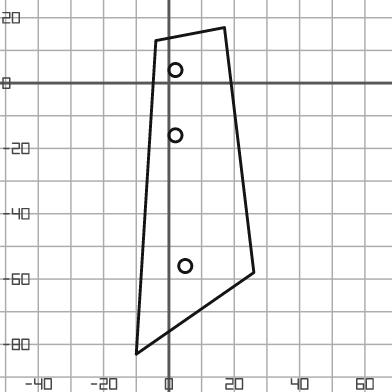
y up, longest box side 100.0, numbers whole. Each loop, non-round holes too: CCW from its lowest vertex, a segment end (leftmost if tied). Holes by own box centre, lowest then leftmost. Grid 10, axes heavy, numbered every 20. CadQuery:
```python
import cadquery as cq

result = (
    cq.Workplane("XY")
    .moveTo(-10.0, -83.0)
    .lineTo(26.0, -58.0)
    .lineTo(17.0, 17.0)
    .lineTo(-4.0, 13.0)
    .close()
    .moveTo(5.0, -56.0)
    .circle(2.0)
    .moveTo(2.0, -16.0)
    .circle(2.0)
    .moveTo(2.0, 4.0)
    .circle(2.0)
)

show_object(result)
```